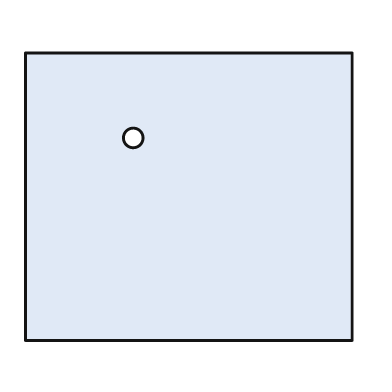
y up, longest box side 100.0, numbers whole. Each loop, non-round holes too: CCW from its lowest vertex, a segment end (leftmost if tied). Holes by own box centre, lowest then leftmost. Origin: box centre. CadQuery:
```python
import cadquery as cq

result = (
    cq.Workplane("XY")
    .moveTo(-50.0, -44.0)
    .lineTo(50.0, -44.0)
    .lineTo(50.0, 44.0)
    .lineTo(-50.0, 44.0)
    .close()
    .moveTo(-17.0, 18.0)
    .circle(3.0)
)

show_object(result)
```